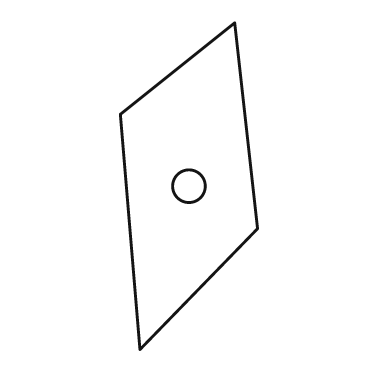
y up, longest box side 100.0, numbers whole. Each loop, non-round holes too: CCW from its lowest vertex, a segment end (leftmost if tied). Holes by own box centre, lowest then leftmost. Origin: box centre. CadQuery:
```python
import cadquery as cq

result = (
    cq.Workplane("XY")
    .moveTo(-15.0, -50.0)
    .lineTo(21.0, -13.0)
    .lineTo(14.0, 50.0)
    .lineTo(-21.0, 22.0)
    .close()
    .moveTo(0.0, 0.0)
    .circle(5.0)
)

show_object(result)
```